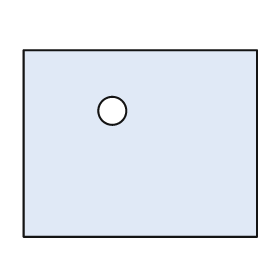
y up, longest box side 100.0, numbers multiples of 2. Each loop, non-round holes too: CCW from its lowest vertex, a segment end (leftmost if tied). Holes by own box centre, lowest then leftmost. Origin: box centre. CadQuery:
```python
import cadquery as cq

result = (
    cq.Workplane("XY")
    .moveTo(-50.0, -40.0)
    .lineTo(50.0, -40.0)
    .lineTo(50.0, 40.0)
    .lineTo(-50.0, 40.0)
    .close()
    .moveTo(-12.0, 14.0)
    .circle(6.0)
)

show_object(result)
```